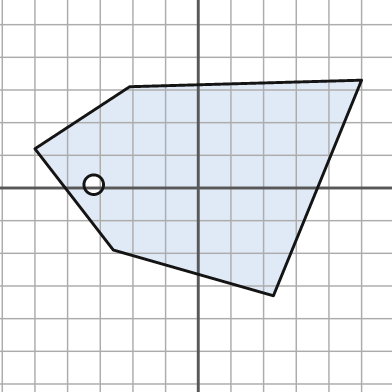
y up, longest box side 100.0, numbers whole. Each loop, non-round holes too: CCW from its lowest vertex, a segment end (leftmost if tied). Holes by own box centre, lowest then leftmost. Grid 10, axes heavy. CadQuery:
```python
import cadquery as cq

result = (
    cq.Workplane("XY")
    .moveTo(23.0, -33.0)
    .lineTo(50.0, 33.0)
    .lineTo(-21.0, 31.0)
    .lineTo(-50.0, 12.0)
    .lineTo(-26.0, -19.0)
    .close()
    .moveTo(-32.0, 1.0)
    .circle(3.0)
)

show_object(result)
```